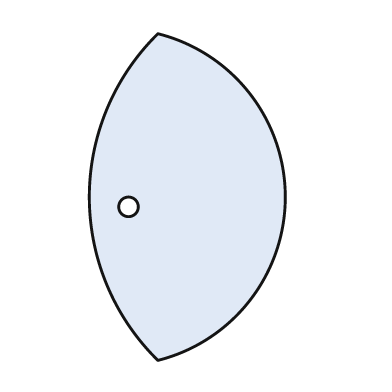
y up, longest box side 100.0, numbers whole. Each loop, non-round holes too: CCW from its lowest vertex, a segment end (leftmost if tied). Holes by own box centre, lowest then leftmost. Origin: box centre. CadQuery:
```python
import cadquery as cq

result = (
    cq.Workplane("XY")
    .moveTo(-9.0, -50.0)
    .threePointArc((30.0, 0.0), (-9.0, 50.0))
    .threePointArc((-30.0, 0.0), (-9.0, -50.0))
    .close()
    .moveTo(-18.0, -3.0)
    .circle(3.0)
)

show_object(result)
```